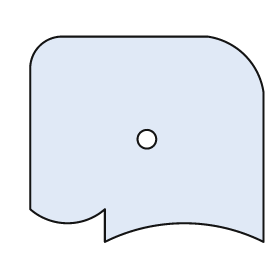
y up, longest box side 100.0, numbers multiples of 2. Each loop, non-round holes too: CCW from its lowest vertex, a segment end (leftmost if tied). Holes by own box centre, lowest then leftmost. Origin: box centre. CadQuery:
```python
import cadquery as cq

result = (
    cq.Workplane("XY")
    .moveTo(-18.0, -44.0)
    .threePointArc((16.0, -36.0), (50.0, -44.0))
    .lineTo(50.0, 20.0)
    .threePointArc((42.0, 36.0), (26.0, 44.0))
    .lineTo(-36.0, 44.0)
    .threePointArc((-46.0, 40.0), (-50.0, 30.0))
    .lineTo(-50.0, -30.0)
    .threePointArc((-34.0, -36.0), (-18.0, -30.0))
    .close()
    .moveTo(0.0, 0.0)
    .circle(4.0)
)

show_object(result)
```